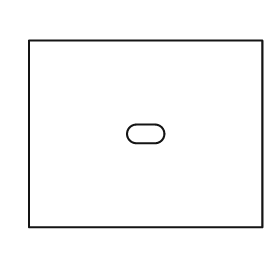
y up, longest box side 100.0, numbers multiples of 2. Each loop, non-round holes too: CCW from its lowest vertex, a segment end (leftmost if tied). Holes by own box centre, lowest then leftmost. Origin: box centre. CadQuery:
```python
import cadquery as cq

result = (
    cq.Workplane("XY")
    .moveTo(-50.0, -40.0)
    .lineTo(50.0, -40.0)
    .lineTo(50.0, 40.0)
    .lineTo(-50.0, 40.0)
    .close()
    .moveTo(-4.0, -4.0)
    .lineTo(4.0, -4.0)
    .threePointArc((8.0, 0.0), (4.0, 4.0))
    .lineTo(-4.0, 4.0)
    .threePointArc((-8.0, 0.0), (-4.0, -4.0))
    .close()
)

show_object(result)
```